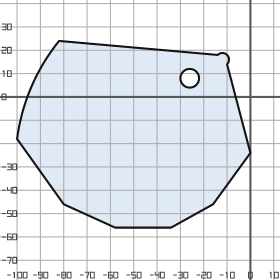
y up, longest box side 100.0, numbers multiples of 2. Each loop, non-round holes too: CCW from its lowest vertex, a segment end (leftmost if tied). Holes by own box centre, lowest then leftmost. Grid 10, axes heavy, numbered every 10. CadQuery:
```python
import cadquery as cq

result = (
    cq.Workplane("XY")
    .moveTo(-58.0, -56.0)
    .lineTo(-34.0, -56.0)
    .lineTo(-16.0, -46.0)
    .lineTo(0.0, -24.0)
    .lineTo(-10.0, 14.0)
    .threePointArc((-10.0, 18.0), (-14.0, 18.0))
    .lineTo(-82.0, 24.0)
    .threePointArc((-94.0, 4.0), (-100.0, -18.0))
    .lineTo(-80.0, -46.0)
    .close()
    .moveTo(-26.0, 8.0)
    .circle(4.0)
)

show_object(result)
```